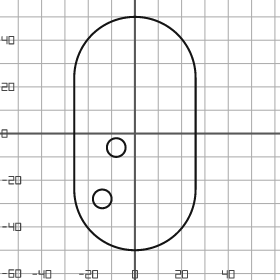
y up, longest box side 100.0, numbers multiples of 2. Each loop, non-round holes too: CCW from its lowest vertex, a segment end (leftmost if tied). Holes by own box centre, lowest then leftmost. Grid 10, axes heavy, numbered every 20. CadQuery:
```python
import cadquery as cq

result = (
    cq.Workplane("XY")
    .moveTo(-26.0, -24.0)
    .threePointArc((0.0, -50.0), (26.0, -24.0))
    .lineTo(26.0, 24.0)
    .threePointArc((0.0, 50.0), (-26.0, 24.0))
    .close()
    .moveTo(-14.0, -28.0)
    .circle(4.0)
    .moveTo(-8.0, -6.0)
    .circle(4.0)
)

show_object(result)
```